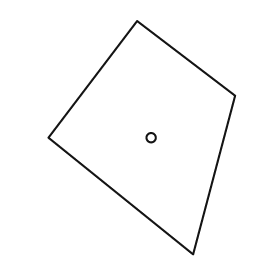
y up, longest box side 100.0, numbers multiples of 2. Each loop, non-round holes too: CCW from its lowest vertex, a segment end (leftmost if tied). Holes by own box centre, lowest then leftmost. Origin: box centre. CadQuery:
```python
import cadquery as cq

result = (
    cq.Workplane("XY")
    .moveTo(22.0, -50.0)
    .lineTo(40.0, 18.0)
    .lineTo(-2.0, 50.0)
    .lineTo(-40.0, 0.0)
    .close()
    .moveTo(4.0, 0.0)
    .circle(2.0)
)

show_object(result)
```